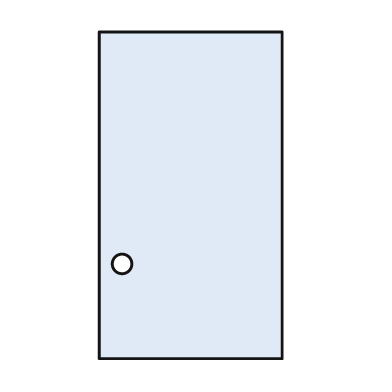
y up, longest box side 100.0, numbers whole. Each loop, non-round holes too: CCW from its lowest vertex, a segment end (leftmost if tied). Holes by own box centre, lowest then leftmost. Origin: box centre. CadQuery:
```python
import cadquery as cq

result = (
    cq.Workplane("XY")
    .moveTo(-28.0, -50.0)
    .lineTo(28.0, -50.0)
    .lineTo(28.0, 50.0)
    .lineTo(-28.0, 50.0)
    .close()
    .moveTo(-21.0, -21.0)
    .circle(3.0)
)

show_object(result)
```